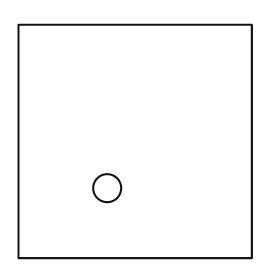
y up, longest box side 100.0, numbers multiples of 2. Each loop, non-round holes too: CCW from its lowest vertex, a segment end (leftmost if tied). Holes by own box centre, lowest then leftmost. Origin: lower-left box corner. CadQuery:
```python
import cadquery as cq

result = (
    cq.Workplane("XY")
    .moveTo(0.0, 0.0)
    .lineTo(100.0, 0.0)
    .lineTo(100.0, 100.0)
    .lineTo(0.0, 100.0)
    .close()
    .moveTo(38.0, 30.0)
    .circle(6.0)
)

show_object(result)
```